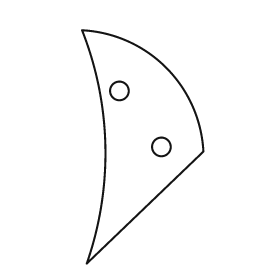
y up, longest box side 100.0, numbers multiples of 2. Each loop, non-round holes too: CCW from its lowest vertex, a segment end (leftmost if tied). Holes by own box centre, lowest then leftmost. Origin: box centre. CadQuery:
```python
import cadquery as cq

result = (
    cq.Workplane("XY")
    .moveTo(-24.0, -50.0)
    .lineTo(26.0, -2.0)
    .threePointArc((10.0, 34.0), (-26.0, 50.0))
    .threePointArc((-16.0, 0.0), (-24.0, -50.0))
    .close()
    .moveTo(8.0, 0.0)
    .circle(4.0)
    .moveTo(-10.0, 24.0)
    .circle(4.0)
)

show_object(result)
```